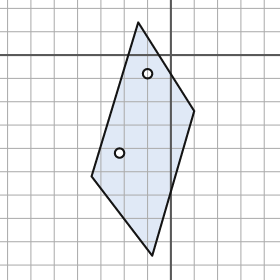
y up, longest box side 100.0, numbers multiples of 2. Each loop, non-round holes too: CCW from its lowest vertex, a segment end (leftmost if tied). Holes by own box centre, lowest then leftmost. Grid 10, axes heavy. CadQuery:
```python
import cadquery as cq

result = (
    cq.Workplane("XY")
    .moveTo(-8.0, -86.0)
    .lineTo(10.0, -24.0)
    .lineTo(-14.0, 14.0)
    .lineTo(-34.0, -52.0)
    .close()
    .moveTo(-22.0, -42.0)
    .circle(2.0)
    .moveTo(-10.0, -8.0)
    .circle(2.0)
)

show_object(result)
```